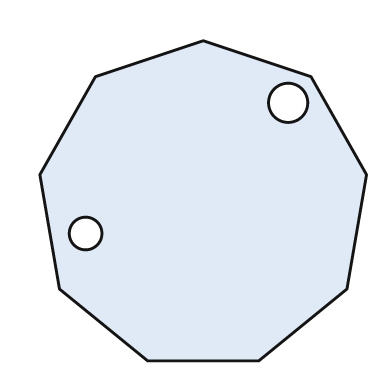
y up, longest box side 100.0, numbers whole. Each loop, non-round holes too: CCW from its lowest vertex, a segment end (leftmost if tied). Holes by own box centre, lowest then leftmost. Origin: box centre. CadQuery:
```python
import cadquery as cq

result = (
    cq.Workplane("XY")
    .moveTo(-17.0, -49.0)
    .lineTo(17.0, -49.0)
    .lineTo(44.0, -27.0)
    .lineTo(50.0, 8.0)
    .lineTo(33.0, 38.0)
    .lineTo(0.0, 49.0)
    .lineTo(-33.0, 38.0)
    .lineTo(-50.0, 8.0)
    .lineTo(-44.0, -27.0)
    .close()
    .moveTo(-36.0, -10.0)
    .circle(5.0)
    .moveTo(26.0, 30.0)
    .circle(6.0)
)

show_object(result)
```